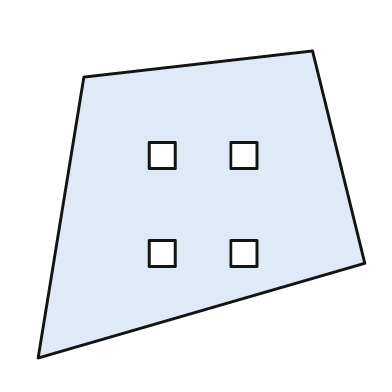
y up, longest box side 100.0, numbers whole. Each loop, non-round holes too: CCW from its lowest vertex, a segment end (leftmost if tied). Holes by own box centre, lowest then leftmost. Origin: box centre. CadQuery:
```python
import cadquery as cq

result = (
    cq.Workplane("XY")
    .moveTo(-50.0, -47.0)
    .lineTo(50.0, -18.0)
    .lineTo(34.0, 47.0)
    .lineTo(-36.0, 39.0)
    .close()
    .moveTo(-16.0, -19.0)
    .lineTo(-8.0, -19.0)
    .lineTo(-8.0, -11.0)
    .lineTo(-16.0, -11.0)
    .close()
    .moveTo(9.0, -19.0)
    .lineTo(17.0, -19.0)
    .lineTo(17.0, -11.0)
    .lineTo(9.0, -11.0)
    .close()
    .moveTo(-16.0, 11.0)
    .lineTo(-8.0, 11.0)
    .lineTo(-8.0, 19.0)
    .lineTo(-16.0, 19.0)
    .close()
    .moveTo(9.0, 11.0)
    .lineTo(17.0, 11.0)
    .lineTo(17.0, 19.0)
    .lineTo(9.0, 19.0)
    .close()
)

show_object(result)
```